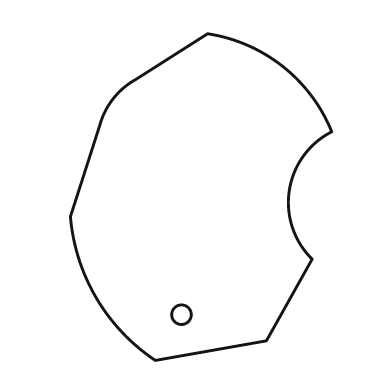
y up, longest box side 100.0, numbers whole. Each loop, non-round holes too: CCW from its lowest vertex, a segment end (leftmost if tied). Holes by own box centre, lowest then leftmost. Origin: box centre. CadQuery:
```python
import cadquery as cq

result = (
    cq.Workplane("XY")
    .moveTo(-14.0, -50.0)
    .lineTo(20.0, -44.0)
    .lineTo(34.0, -19.0)
    .threePointArc((27.0, 2.0), (40.0, 20.0))
    .threePointArc((25.0, 40.0), (2.0, 50.0))
    .lineTo(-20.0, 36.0)
    .threePointArc((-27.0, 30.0), (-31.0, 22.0))
    .lineTo(-40.0, -6.0)
    .threePointArc((-32.0, -31.0), (-14.0, -50.0))
    .close()
    .moveTo(-6.0, -36.0)
    .circle(3.0)
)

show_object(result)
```